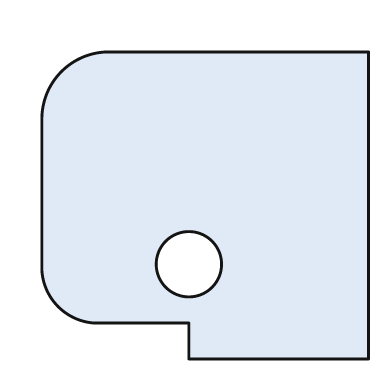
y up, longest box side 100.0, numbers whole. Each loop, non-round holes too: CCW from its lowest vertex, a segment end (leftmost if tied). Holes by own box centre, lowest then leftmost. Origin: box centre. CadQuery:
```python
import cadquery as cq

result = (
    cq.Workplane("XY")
    .moveTo(-5.0, -47.0)
    .lineTo(50.0, -47.0)
    .lineTo(50.0, 47.0)
    .lineTo(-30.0, 47.0)
    .threePointArc((-44.0, 41.0), (-50.0, 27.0))
    .lineTo(-50.0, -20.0)
    .threePointArc((-45.0, -31.0), (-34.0, -36.0))
    .lineTo(-5.0, -36.0)
    .close()
    .moveTo(-5.0, -18.0)
    .circle(10.0)
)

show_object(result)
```